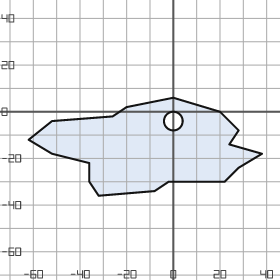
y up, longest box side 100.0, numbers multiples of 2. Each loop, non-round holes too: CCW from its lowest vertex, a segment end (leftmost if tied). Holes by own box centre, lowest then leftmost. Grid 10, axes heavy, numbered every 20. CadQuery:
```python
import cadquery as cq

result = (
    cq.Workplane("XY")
    .moveTo(-32.0, -36.0)
    .lineTo(-8.0, -34.0)
    .lineTo(-2.0, -30.0)
    .lineTo(22.0, -30.0)
    .lineTo(28.0, -24.0)
    .lineTo(38.0, -18.0)
    .lineTo(24.0, -14.0)
    .lineTo(28.0, -8.0)
    .lineTo(20.0, 0.0)
    .lineTo(0.0, 6.0)
    .lineTo(-20.0, 2.0)
    .lineTo(-26.0, -2.0)
    .lineTo(-52.0, -4.0)
    .lineTo(-62.0, -12.0)
    .lineTo(-52.0, -18.0)
    .lineTo(-36.0, -22.0)
    .lineTo(-36.0, -30.0)
    .close()
    .moveTo(0.0, -4.0)
    .circle(4.0)
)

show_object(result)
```